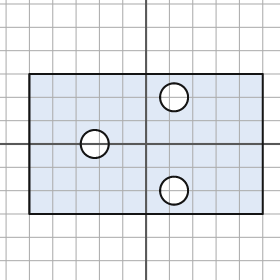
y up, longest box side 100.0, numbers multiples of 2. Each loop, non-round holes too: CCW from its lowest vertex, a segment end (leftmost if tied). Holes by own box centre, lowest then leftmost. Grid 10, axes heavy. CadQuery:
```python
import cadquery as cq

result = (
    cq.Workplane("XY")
    .moveTo(-50.0, -30.0)
    .lineTo(50.0, -30.0)
    .lineTo(50.0, 30.0)
    .lineTo(-50.0, 30.0)
    .close()
    .moveTo(12.0, -20.0)
    .circle(6.0)
    .moveTo(-22.0, 0.0)
    .circle(6.0)
    .moveTo(12.0, 20.0)
    .circle(6.0)
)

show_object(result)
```